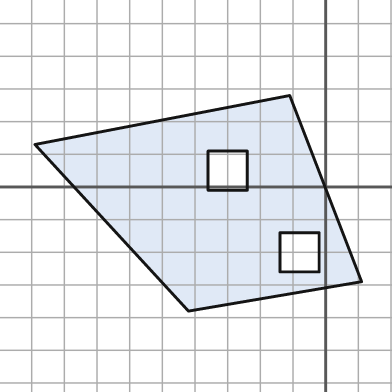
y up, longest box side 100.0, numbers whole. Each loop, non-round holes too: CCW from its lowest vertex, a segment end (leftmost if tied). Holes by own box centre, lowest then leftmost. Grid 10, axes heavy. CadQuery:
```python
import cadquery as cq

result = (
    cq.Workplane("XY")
    .moveTo(-42.0, -38.0)
    .lineTo(11.0, -29.0)
    .lineTo(-11.0, 28.0)
    .lineTo(-89.0, 13.0)
    .close()
    .moveTo(-14.0, -26.0)
    .lineTo(-2.0, -26.0)
    .lineTo(-2.0, -14.0)
    .lineTo(-14.0, -14.0)
    .close()
    .moveTo(-36.0, -1.0)
    .lineTo(-24.0, -1.0)
    .lineTo(-24.0, 11.0)
    .lineTo(-36.0, 11.0)
    .close()
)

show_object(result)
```